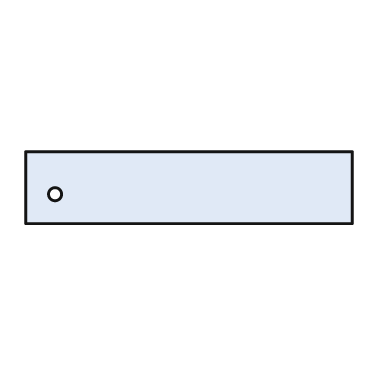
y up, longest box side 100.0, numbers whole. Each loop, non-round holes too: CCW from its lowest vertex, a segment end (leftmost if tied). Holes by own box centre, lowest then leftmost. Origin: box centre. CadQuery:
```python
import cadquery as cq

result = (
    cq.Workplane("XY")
    .moveTo(-50.0, -11.0)
    .lineTo(50.0, -11.0)
    .lineTo(50.0, 11.0)
    .lineTo(-50.0, 11.0)
    .close()
    .moveTo(-41.0, -2.0)
    .circle(2.0)
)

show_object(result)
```